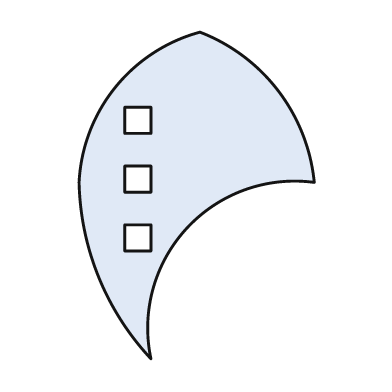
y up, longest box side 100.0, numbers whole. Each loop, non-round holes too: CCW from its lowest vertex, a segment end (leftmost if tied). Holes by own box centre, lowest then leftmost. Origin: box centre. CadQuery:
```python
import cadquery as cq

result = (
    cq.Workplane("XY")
    .moveTo(-14.0, -50.0)
    .threePointArc((-3.0, -10.0), (36.0, 4.0))
    .threePointArc((25.0, 32.0), (1.0, 50.0))
    .threePointArc((-25.0, 33.0), (-36.0, 4.0))
    .threePointArc((-30.0, -25.0), (-14.0, -50.0))
    .close()
    .moveTo(-22.0, -17.0)
    .lineTo(-14.0, -17.0)
    .lineTo(-14.0, -9.0)
    .lineTo(-22.0, -9.0)
    .close()
    .moveTo(-22.0, 1.0)
    .lineTo(-14.0, 1.0)
    .lineTo(-14.0, 9.0)
    .lineTo(-22.0, 9.0)
    .close()
    .moveTo(-22.0, 19.0)
    .lineTo(-14.0, 19.0)
    .lineTo(-14.0, 27.0)
    .lineTo(-22.0, 27.0)
    .close()
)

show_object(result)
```